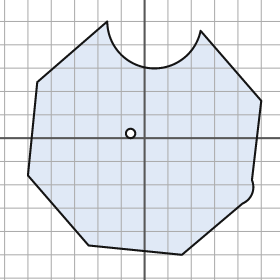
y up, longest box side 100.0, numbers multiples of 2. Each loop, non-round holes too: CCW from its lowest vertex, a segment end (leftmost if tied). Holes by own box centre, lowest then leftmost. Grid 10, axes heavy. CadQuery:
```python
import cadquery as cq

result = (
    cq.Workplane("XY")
    .moveTo(16.0, -50.0)
    .lineTo(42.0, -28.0)
    .threePointArc((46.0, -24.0), (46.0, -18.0))
    .lineTo(50.0, 16.0)
    .lineTo(24.0, 46.0)
    .threePointArc((2.0, 30.0), (-16.0, 50.0))
    .lineTo(-46.0, 24.0)
    .lineTo(-50.0, -16.0)
    .lineTo(-24.0, -46.0)
    .close()
    .moveTo(-6.0, 2.0)
    .circle(2.0)
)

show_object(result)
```